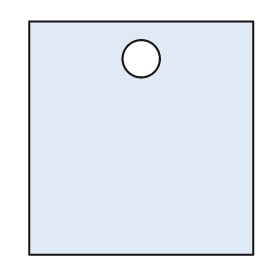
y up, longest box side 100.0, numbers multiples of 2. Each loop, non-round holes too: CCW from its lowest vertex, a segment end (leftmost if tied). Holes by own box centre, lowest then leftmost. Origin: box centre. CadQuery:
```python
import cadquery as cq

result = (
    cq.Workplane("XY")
    .moveTo(-48.0, -50.0)
    .lineTo(48.0, -50.0)
    .lineTo(48.0, 50.0)
    .lineTo(-48.0, 50.0)
    .close()
    .moveTo(0.0, 34.0)
    .circle(8.0)
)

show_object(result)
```